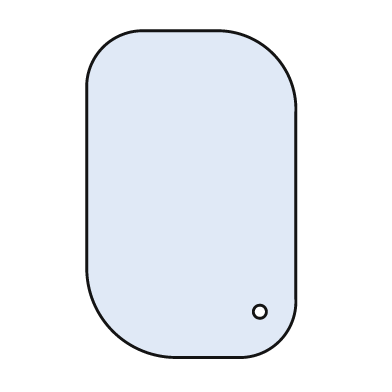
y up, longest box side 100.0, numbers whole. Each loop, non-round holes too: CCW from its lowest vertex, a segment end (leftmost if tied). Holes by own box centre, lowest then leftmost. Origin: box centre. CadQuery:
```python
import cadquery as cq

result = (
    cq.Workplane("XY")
    .moveTo(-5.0, -50.0)
    .lineTo(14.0, -50.0)
    .threePointArc((27.0, -45.0), (32.0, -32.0))
    .lineTo(32.0, 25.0)
    .threePointArc((25.0, 43.0), (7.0, 50.0))
    .lineTo(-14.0, 50.0)
    .threePointArc((-27.0, 45.0), (-32.0, 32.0))
    .lineTo(-32.0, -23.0)
    .threePointArc((-24.0, -42.0), (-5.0, -50.0))
    .close()
    .moveTo(21.0, -36.0)
    .circle(2.0)
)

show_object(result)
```